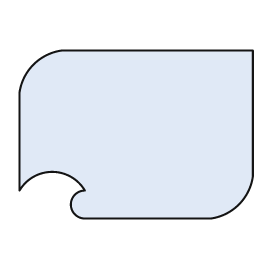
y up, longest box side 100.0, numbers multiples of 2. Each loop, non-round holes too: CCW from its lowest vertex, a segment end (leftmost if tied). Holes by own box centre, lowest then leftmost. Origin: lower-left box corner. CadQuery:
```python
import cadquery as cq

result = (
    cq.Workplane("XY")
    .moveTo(28.0, 0.0)
    .lineTo(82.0, 0.0)
    .threePointArc((94.0, 6.0), (100.0, 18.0))
    .lineTo(100.0, 72.0)
    .lineTo(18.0, 72.0)
    .threePointArc((6.0, 66.0), (0.0, 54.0))
    .lineTo(0.0, 12.0)
    .threePointArc((14.0, 20.0), (28.0, 12.0))
    .threePointArc((22.0, 6.0), (28.0, 0.0))
    .close()
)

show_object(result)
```